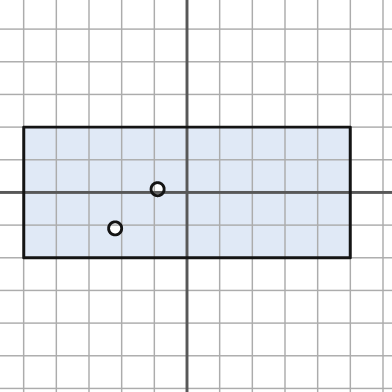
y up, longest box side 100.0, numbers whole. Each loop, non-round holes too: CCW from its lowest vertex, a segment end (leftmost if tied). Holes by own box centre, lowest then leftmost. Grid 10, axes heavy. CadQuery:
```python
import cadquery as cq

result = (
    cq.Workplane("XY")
    .moveTo(-50.0, -20.0)
    .lineTo(50.0, -20.0)
    .lineTo(50.0, 20.0)
    .lineTo(-50.0, 20.0)
    .close()
    .moveTo(-22.0, -11.0)
    .circle(2.0)
    .moveTo(-9.0, 1.0)
    .circle(2.0)
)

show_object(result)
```